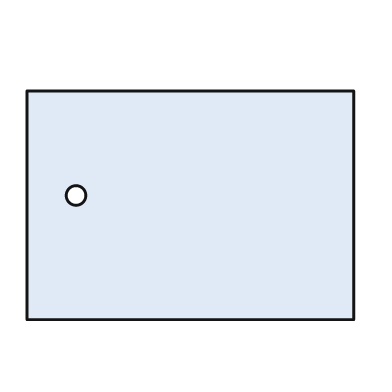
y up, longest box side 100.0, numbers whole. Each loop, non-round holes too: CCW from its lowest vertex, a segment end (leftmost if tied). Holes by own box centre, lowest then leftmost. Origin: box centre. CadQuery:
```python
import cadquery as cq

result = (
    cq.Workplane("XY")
    .moveTo(-50.0, -35.0)
    .lineTo(50.0, -35.0)
    .lineTo(50.0, 35.0)
    .lineTo(-50.0, 35.0)
    .close()
    .moveTo(-35.0, 3.0)
    .circle(3.0)
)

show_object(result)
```